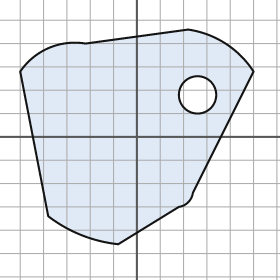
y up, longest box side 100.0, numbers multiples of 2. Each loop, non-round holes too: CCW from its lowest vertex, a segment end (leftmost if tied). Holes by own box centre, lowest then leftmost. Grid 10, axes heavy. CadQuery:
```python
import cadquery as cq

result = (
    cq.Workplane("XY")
    .moveTo(-8.0, -46.0)
    .lineTo(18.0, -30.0)
    .threePointArc((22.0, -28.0), (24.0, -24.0))
    .lineTo(50.0, 28.0)
    .threePointArc((38.0, 40.0), (22.0, 46.0))
    .lineTo(-22.0, 40.0)
    .threePointArc((-38.0, 38.0), (-50.0, 28.0))
    .lineTo(-38.0, -34.0)
    .threePointArc((-24.0, -42.0), (-8.0, -46.0))
    .close()
    .moveTo(26.0, 18.0)
    .circle(8.0)
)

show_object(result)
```